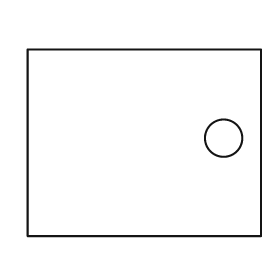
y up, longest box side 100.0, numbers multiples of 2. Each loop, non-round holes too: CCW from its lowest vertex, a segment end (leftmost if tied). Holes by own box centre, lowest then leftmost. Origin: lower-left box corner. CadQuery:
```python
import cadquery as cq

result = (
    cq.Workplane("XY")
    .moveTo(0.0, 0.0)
    .lineTo(100.0, 0.0)
    .lineTo(100.0, 80.0)
    .lineTo(0.0, 80.0)
    .close()
    .moveTo(84.0, 42.0)
    .circle(8.0)
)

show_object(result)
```